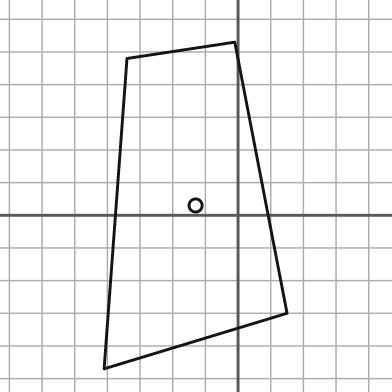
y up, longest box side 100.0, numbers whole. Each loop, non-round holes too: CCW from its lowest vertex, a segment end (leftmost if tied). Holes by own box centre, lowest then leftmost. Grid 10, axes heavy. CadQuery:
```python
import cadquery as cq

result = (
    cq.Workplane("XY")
    .moveTo(-41.0, -47.0)
    .lineTo(15.0, -30.0)
    .lineTo(-1.0, 53.0)
    .lineTo(-34.0, 48.0)
    .close()
    .moveTo(-13.0, 3.0)
    .circle(2.0)
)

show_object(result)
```